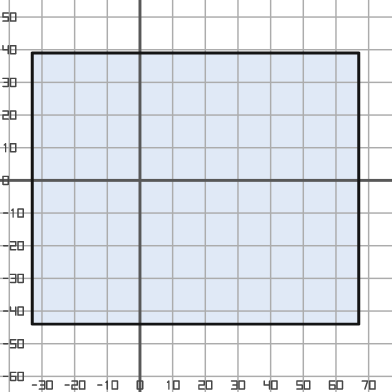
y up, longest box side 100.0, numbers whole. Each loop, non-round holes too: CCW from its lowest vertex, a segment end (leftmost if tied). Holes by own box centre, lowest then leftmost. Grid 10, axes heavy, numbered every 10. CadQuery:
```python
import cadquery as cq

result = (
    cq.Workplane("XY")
    .moveTo(-33.0, -44.0)
    .lineTo(67.0, -44.0)
    .lineTo(67.0, 39.0)
    .lineTo(-33.0, 39.0)
    .close()
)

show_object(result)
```